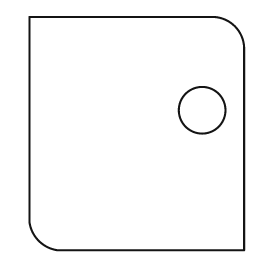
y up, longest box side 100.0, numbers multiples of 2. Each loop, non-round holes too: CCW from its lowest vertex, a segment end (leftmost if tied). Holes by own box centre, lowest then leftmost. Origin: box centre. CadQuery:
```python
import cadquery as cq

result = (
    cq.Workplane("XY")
    .moveTo(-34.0, -50.0)
    .lineTo(46.0, -50.0)
    .lineTo(46.0, 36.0)
    .threePointArc((42.0, 46.0), (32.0, 50.0))
    .lineTo(-46.0, 50.0)
    .lineTo(-46.0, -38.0)
    .threePointArc((-42.0, -46.0), (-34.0, -50.0))
    .close()
    .moveTo(28.0, 10.0)
    .circle(10.0)
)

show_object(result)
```